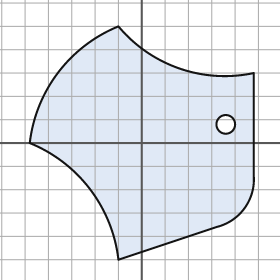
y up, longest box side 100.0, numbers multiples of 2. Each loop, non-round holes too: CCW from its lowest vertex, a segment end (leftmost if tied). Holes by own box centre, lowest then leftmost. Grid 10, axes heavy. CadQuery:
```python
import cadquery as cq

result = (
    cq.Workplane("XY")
    .moveTo(-10.0, -50.0)
    .lineTo(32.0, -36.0)
    .threePointArc((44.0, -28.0), (48.0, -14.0))
    .lineTo(48.0, 30.0)
    .threePointArc((16.0, 32.0), (-10.0, 50.0))
    .threePointArc((-36.0, 30.0), (-48.0, 0.0))
    .threePointArc((-22.0, -20.0), (-10.0, -50.0))
    .close()
    .moveTo(36.0, 8.0)
    .circle(4.0)
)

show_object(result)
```